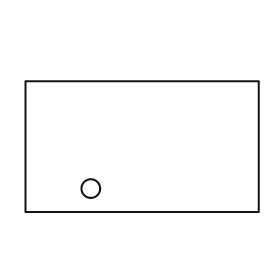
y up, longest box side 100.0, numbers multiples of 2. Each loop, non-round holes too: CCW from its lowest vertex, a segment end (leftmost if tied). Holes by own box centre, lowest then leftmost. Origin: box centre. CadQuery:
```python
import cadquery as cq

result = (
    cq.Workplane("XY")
    .moveTo(-50.0, -28.0)
    .lineTo(50.0, -28.0)
    .lineTo(50.0, 28.0)
    .lineTo(-50.0, 28.0)
    .close()
    .moveTo(-22.0, -18.0)
    .circle(4.0)
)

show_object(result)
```